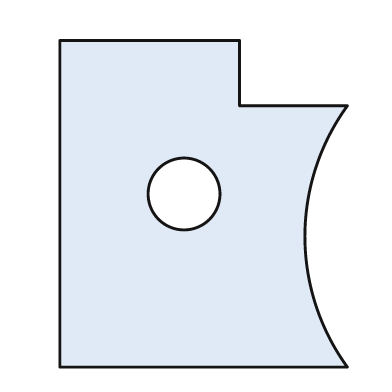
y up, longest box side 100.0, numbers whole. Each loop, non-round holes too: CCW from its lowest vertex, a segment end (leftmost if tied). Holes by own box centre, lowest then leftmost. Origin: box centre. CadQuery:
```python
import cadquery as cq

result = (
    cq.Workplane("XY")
    .moveTo(-44.0, -50.0)
    .lineTo(44.0, -50.0)
    .threePointArc((31.0, -10.0), (44.0, 30.0))
    .lineTo(11.0, 30.0)
    .lineTo(11.0, 50.0)
    .lineTo(-44.0, 50.0)
    .close()
    .moveTo(-6.0, 3.0)
    .circle(11.0)
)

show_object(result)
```